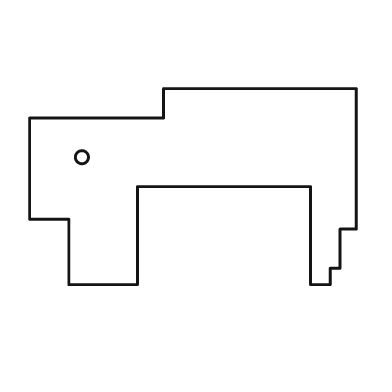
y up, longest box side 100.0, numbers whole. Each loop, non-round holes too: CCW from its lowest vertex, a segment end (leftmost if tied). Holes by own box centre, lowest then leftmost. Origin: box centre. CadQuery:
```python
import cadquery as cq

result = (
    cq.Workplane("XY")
    .moveTo(-38.0, -30.0)
    .lineTo(-17.0, -30.0)
    .lineTo(-17.0, 0.0)
    .lineTo(36.0, 0.0)
    .lineTo(36.0, -30.0)
    .lineTo(42.0, -30.0)
    .lineTo(42.0, -25.0)
    .lineTo(45.0, -25.0)
    .lineTo(45.0, -13.0)
    .lineTo(50.0, -13.0)
    .lineTo(50.0, 30.0)
    .lineTo(-9.0, 30.0)
    .lineTo(-9.0, 21.0)
    .lineTo(-50.0, 21.0)
    .lineTo(-50.0, -10.0)
    .lineTo(-38.0, -10.0)
    .close()
    .moveTo(-34.0, 9.0)
    .circle(2.0)
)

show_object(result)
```